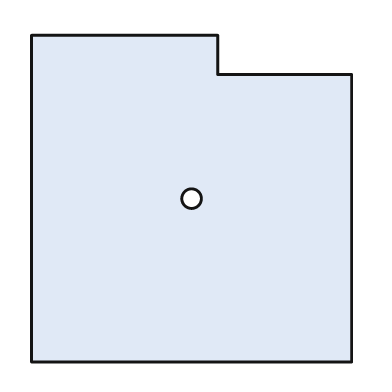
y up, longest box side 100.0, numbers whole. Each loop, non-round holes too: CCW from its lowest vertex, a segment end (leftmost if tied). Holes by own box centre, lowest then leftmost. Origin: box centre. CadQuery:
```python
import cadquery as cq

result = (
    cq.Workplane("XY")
    .moveTo(-49.0, -50.0)
    .lineTo(49.0, -50.0)
    .lineTo(49.0, 38.0)
    .lineTo(8.0, 38.0)
    .lineTo(8.0, 50.0)
    .lineTo(-49.0, 50.0)
    .close()
    .moveTo(0.0, 0.0)
    .circle(3.0)
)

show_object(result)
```